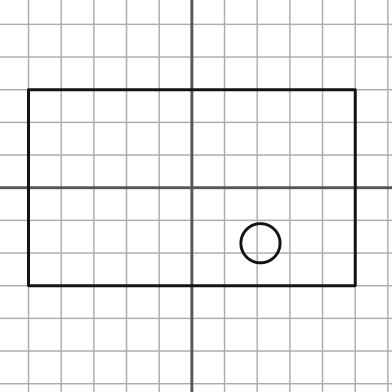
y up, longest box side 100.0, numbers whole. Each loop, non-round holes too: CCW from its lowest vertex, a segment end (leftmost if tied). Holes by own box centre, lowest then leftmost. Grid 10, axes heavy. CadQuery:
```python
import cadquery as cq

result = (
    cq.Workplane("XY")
    .moveTo(-50.0, -30.0)
    .lineTo(50.0, -30.0)
    .lineTo(50.0, 30.0)
    .lineTo(-50.0, 30.0)
    .close()
    .moveTo(21.0, -17.0)
    .circle(6.0)
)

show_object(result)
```